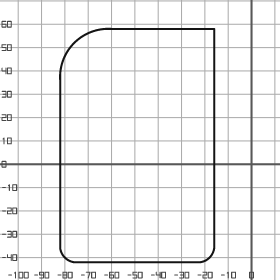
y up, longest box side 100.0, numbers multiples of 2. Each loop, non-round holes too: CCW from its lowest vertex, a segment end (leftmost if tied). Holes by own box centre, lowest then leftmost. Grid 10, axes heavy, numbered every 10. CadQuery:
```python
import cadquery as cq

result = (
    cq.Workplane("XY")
    .moveTo(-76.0, -42.0)
    .lineTo(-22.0, -42.0)
    .threePointArc((-18.0, -40.0), (-16.0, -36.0))
    .lineTo(-16.0, 58.0)
    .lineTo(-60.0, 58.0)
    .threePointArc((-76.0, 52.0), (-82.0, 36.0))
    .lineTo(-82.0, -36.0)
    .threePointArc((-80.0, -40.0), (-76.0, -42.0))
    .close()
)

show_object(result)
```